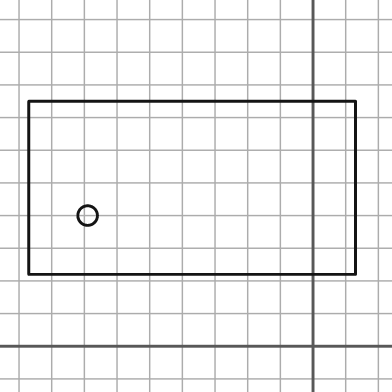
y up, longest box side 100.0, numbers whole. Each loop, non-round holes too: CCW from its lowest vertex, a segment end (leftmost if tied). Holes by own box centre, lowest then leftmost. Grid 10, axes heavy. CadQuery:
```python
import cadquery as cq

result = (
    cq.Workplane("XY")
    .moveTo(-87.0, 22.0)
    .lineTo(13.0, 22.0)
    .lineTo(13.0, 75.0)
    .lineTo(-87.0, 75.0)
    .close()
    .moveTo(-69.0, 40.0)
    .circle(3.0)
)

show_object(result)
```